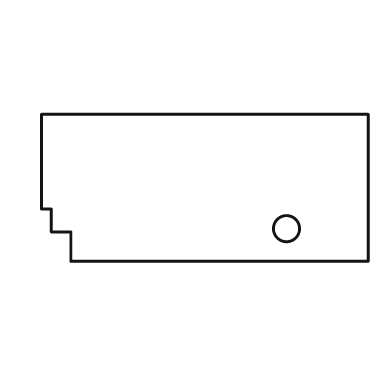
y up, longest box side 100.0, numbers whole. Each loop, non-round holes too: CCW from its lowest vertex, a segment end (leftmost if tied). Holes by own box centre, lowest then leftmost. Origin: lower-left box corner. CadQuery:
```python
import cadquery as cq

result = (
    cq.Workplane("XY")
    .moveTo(9.0, 0.0)
    .lineTo(100.0, 0.0)
    .lineTo(100.0, 45.0)
    .lineTo(0.0, 45.0)
    .lineTo(0.0, 16.0)
    .lineTo(3.0, 16.0)
    .lineTo(3.0, 9.0)
    .lineTo(9.0, 9.0)
    .close()
    .moveTo(75.0, 10.0)
    .circle(4.0)
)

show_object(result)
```